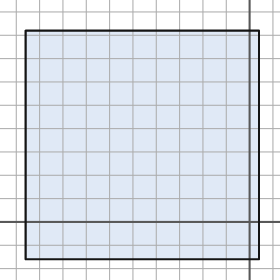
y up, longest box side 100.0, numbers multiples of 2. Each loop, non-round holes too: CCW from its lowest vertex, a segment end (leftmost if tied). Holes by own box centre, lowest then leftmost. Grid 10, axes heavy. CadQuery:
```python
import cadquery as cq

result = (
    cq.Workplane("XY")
    .moveTo(-96.0, -16.0)
    .lineTo(4.0, -16.0)
    .lineTo(4.0, 82.0)
    .lineTo(-96.0, 82.0)
    .close()
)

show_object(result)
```